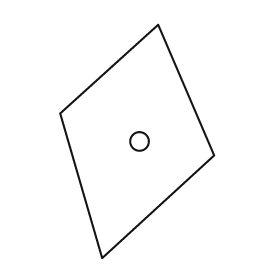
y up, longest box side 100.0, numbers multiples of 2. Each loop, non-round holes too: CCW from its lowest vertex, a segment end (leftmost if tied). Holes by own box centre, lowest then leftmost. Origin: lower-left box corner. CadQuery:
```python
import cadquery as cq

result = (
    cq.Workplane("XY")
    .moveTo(18.0, 0.0)
    .lineTo(66.0, 44.0)
    .lineTo(42.0, 100.0)
    .lineTo(0.0, 62.0)
    .close()
    .moveTo(34.0, 50.0)
    .circle(4.0)
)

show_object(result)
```